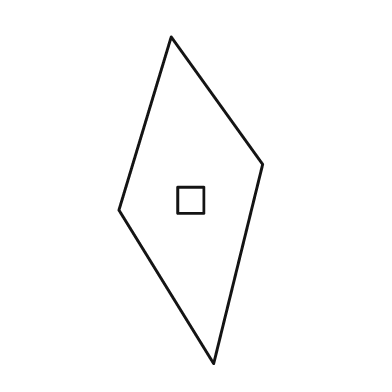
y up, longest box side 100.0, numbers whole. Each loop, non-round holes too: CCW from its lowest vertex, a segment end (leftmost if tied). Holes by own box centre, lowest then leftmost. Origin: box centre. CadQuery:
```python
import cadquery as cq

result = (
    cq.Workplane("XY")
    .moveTo(7.0, -50.0)
    .lineTo(22.0, 11.0)
    .lineTo(-6.0, 50.0)
    .lineTo(-22.0, -3.0)
    .close()
    .moveTo(-4.0, -4.0)
    .lineTo(4.0, -4.0)
    .lineTo(4.0, 4.0)
    .lineTo(-4.0, 4.0)
    .close()
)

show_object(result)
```